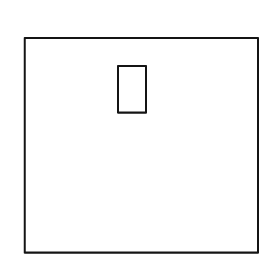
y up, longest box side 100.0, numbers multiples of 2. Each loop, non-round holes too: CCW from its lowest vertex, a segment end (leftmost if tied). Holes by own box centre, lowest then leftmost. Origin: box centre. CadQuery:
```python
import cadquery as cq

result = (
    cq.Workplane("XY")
    .moveTo(-50.0, -46.0)
    .lineTo(50.0, -46.0)
    .lineTo(50.0, 46.0)
    .lineTo(-50.0, 46.0)
    .close()
    .moveTo(-10.0, 14.0)
    .lineTo(2.0, 14.0)
    .lineTo(2.0, 34.0)
    .lineTo(-10.0, 34.0)
    .close()
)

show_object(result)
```